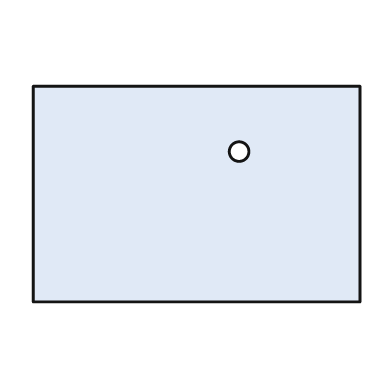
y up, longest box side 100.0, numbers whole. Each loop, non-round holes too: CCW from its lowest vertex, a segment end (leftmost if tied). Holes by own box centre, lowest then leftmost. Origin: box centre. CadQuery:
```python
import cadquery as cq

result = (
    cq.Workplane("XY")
    .moveTo(-50.0, -33.0)
    .lineTo(50.0, -33.0)
    .lineTo(50.0, 33.0)
    .lineTo(-50.0, 33.0)
    .close()
    .moveTo(13.0, 13.0)
    .circle(3.0)
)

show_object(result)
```